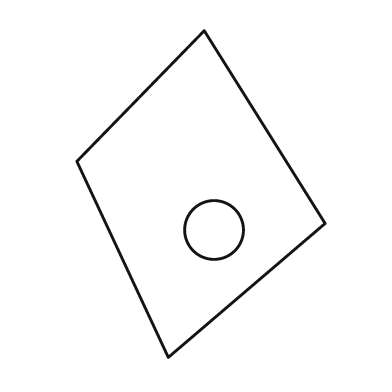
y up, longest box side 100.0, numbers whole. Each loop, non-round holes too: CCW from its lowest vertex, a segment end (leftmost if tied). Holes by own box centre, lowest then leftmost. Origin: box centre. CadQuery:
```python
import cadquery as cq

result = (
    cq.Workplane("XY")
    .moveTo(-10.0, -50.0)
    .lineTo(38.0, -9.0)
    .lineTo(1.0, 50.0)
    .lineTo(-38.0, 10.0)
    .close()
    .moveTo(4.0, -11.0)
    .circle(9.0)
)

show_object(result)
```